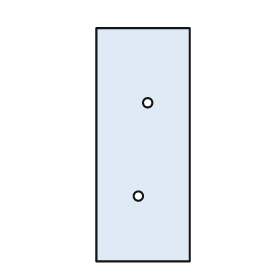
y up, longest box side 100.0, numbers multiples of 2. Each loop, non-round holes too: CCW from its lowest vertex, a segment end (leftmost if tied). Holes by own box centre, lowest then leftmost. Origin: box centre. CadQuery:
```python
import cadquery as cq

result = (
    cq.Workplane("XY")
    .moveTo(-20.0, -50.0)
    .lineTo(20.0, -50.0)
    .lineTo(20.0, 50.0)
    .lineTo(-20.0, 50.0)
    .close()
    .moveTo(-2.0, -22.0)
    .circle(2.0)
    .moveTo(2.0, 18.0)
    .circle(2.0)
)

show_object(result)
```